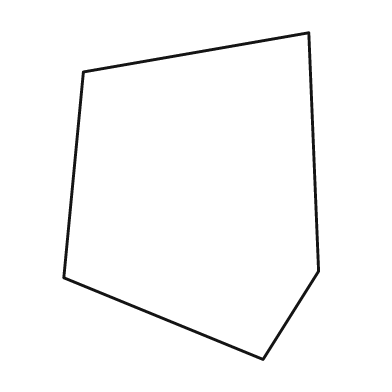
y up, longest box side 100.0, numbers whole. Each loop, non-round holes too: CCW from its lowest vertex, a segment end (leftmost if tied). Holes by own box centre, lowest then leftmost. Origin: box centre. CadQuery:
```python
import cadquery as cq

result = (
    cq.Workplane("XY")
    .moveTo(22.0, -50.0)
    .lineTo(39.0, -23.0)
    .lineTo(36.0, 50.0)
    .lineTo(-33.0, 38.0)
    .lineTo(-39.0, -25.0)
    .close()
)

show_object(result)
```